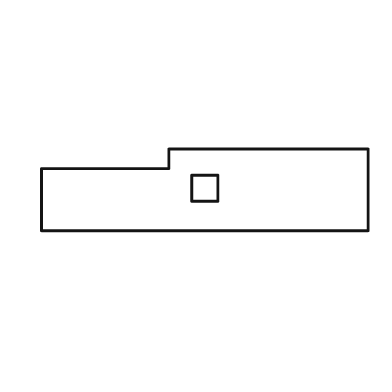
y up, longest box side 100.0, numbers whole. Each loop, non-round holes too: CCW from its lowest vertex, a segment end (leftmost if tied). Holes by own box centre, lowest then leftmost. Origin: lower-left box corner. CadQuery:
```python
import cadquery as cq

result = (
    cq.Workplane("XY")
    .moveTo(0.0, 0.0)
    .lineTo(100.0, 0.0)
    .lineTo(100.0, 25.0)
    .lineTo(39.0, 25.0)
    .lineTo(39.0, 19.0)
    .lineTo(0.0, 19.0)
    .close()
    .moveTo(46.0, 9.0)
    .lineTo(54.0, 9.0)
    .lineTo(54.0, 17.0)
    .lineTo(46.0, 17.0)
    .close()
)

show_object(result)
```